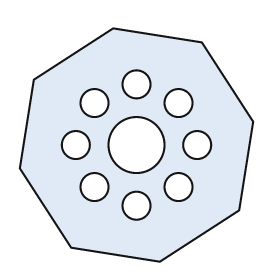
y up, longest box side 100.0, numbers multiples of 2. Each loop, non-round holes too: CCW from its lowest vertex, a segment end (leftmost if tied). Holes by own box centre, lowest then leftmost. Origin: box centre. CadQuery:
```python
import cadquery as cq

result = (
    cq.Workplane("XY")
    .moveTo(10.0, -50.0)
    .lineTo(44.0, -28.0)
    .lineTo(50.0, 10.0)
    .lineTo(28.0, 44.0)
    .lineTo(-10.0, 50.0)
    .lineTo(-44.0, 28.0)
    .lineTo(-50.0, -10.0)
    .lineTo(-28.0, -44.0)
    .close()
    .moveTo(0.0, -26.0)
    .circle(6.0)
    .moveTo(-18.0, -18.0)
    .circle(6.0)
    .moveTo(18.0, -18.0)
    .circle(6.0)
    .moveTo(-26.0, 0.0)
    .circle(6.0)
    .moveTo(0.0, 0.0)
    .circle(12.0)
    .moveTo(26.0, 0.0)
    .circle(6.0)
    .moveTo(-18.0, 18.0)
    .circle(6.0)
    .moveTo(18.0, 18.0)
    .circle(6.0)
    .moveTo(0.0, 26.0)
    .circle(6.0)
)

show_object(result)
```